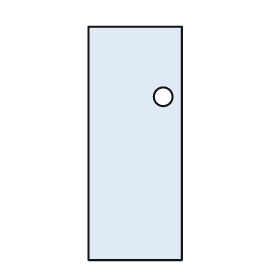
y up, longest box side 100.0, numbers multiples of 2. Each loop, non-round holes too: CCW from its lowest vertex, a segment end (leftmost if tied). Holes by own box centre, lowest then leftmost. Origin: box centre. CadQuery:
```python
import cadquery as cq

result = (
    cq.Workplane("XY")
    .moveTo(-20.0, -50.0)
    .lineTo(20.0, -50.0)
    .lineTo(20.0, 50.0)
    .lineTo(-20.0, 50.0)
    .close()
    .moveTo(12.0, 20.0)
    .circle(4.0)
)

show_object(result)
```